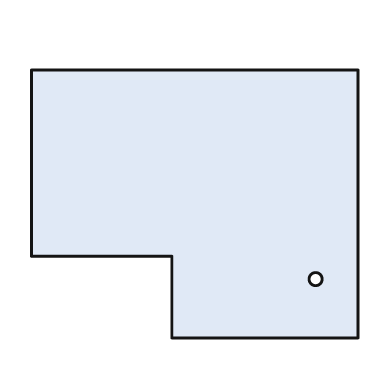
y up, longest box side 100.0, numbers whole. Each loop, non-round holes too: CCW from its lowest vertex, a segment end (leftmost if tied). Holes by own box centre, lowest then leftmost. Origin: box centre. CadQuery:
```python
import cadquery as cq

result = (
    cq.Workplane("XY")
    .moveTo(-7.0, -41.0)
    .lineTo(50.0, -41.0)
    .lineTo(50.0, 41.0)
    .lineTo(-50.0, 41.0)
    .lineTo(-50.0, -16.0)
    .lineTo(-7.0, -16.0)
    .close()
    .moveTo(37.0, -23.0)
    .circle(2.0)
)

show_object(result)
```